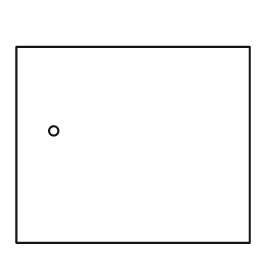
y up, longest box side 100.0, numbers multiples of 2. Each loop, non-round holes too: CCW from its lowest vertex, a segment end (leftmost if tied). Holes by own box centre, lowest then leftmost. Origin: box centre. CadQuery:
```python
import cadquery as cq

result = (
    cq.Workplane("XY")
    .moveTo(-50.0, -42.0)
    .lineTo(50.0, -42.0)
    .lineTo(50.0, 42.0)
    .lineTo(-50.0, 42.0)
    .close()
    .moveTo(-34.0, 6.0)
    .circle(2.0)
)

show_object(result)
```